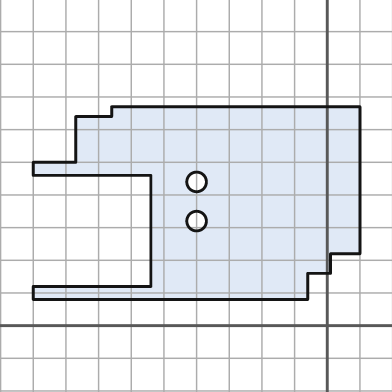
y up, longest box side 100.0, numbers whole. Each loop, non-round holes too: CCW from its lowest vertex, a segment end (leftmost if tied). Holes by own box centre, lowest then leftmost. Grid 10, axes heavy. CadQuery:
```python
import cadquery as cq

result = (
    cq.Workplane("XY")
    .moveTo(-90.0, 8.0)
    .lineTo(-6.0, 8.0)
    .lineTo(-6.0, 16.0)
    .lineTo(1.0, 16.0)
    .lineTo(1.0, 22.0)
    .lineTo(10.0, 22.0)
    .lineTo(10.0, 67.0)
    .lineTo(-66.0, 67.0)
    .lineTo(-66.0, 64.0)
    .lineTo(-77.0, 64.0)
    .lineTo(-77.0, 50.0)
    .lineTo(-90.0, 50.0)
    .lineTo(-90.0, 46.0)
    .lineTo(-54.0, 46.0)
    .lineTo(-54.0, 12.0)
    .lineTo(-90.0, 12.0)
    .close()
    .moveTo(-40.0, 32.0)
    .circle(3.0)
    .moveTo(-40.0, 44.0)
    .circle(3.0)
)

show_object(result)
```